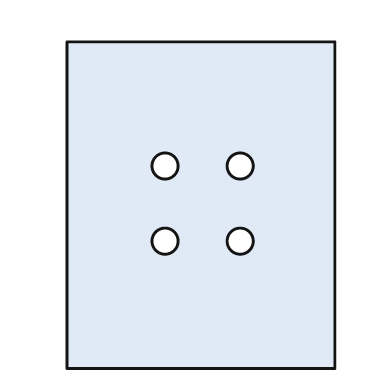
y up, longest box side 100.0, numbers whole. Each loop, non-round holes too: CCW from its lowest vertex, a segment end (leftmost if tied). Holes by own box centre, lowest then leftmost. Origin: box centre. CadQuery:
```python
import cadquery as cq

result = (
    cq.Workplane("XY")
    .moveTo(-41.0, -50.0)
    .lineTo(41.0, -50.0)
    .lineTo(41.0, 50.0)
    .lineTo(-41.0, 50.0)
    .close()
    .moveTo(-11.0, -11.0)
    .circle(4.0)
    .moveTo(12.0, -11.0)
    .circle(4.0)
    .moveTo(-11.0, 12.0)
    .circle(4.0)
    .moveTo(12.0, 12.0)
    .circle(4.0)
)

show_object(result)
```